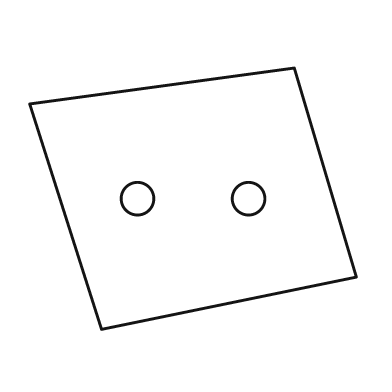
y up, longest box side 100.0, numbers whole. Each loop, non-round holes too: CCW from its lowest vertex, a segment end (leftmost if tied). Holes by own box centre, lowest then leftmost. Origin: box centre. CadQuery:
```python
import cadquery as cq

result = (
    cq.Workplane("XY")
    .moveTo(-28.0, -40.0)
    .lineTo(50.0, -24.0)
    .lineTo(31.0, 40.0)
    .lineTo(-50.0, 29.0)
    .close()
    .moveTo(-17.0, 0.0)
    .circle(5.0)
    .moveTo(17.0, 0.0)
    .circle(5.0)
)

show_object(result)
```